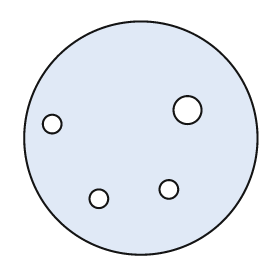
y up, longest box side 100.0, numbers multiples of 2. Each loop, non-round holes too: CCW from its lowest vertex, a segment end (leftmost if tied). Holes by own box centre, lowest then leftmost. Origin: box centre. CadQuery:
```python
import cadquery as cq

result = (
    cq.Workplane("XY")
    .moveTo(0.0, 0.0)
    .circle(50.0)
    .moveTo(-18.0, -26.0)
    .circle(4.0)
    .moveTo(12.0, -22.0)
    .circle(4.0)
    .moveTo(-38.0, 6.0)
    .circle(4.0)
    .moveTo(20.0, 12.0)
    .circle(6.0)
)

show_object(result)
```